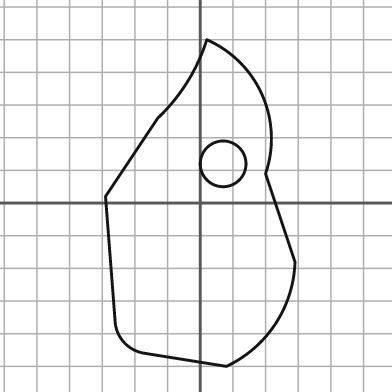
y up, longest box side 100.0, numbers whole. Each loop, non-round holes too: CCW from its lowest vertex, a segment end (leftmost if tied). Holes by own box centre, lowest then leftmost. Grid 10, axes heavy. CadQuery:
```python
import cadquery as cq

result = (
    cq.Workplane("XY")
    .moveTo(8.0, -50.0)
    .threePointArc((23.0, -37.0), (29.0, -18.0))
    .lineTo(20.0, 9.0)
    .threePointArc((19.0, 33.0), (2.0, 50.0))
    .threePointArc((-4.0, 37.0), (-13.0, 26.0))
    .lineTo(-29.0, 2.0)
    .lineTo(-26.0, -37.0)
    .threePointArc((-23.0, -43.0), (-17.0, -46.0))
    .close()
    .moveTo(7.0, 12.0)
    .circle(7.0)
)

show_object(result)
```